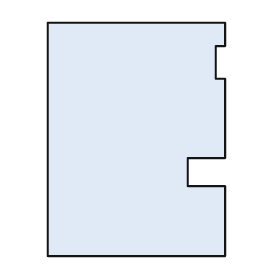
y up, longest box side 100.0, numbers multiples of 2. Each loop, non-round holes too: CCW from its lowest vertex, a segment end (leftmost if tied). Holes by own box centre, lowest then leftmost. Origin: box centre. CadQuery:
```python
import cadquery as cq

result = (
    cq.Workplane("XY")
    .moveTo(-38.0, -50.0)
    .lineTo(38.0, -50.0)
    .lineTo(38.0, -20.0)
    .lineTo(22.0, -20.0)
    .lineTo(22.0, -8.0)
    .lineTo(38.0, -8.0)
    .lineTo(38.0, 26.0)
    .lineTo(34.0, 26.0)
    .lineTo(34.0, 40.0)
    .lineTo(38.0, 40.0)
    .lineTo(38.0, 50.0)
    .lineTo(-38.0, 50.0)
    .close()
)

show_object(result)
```